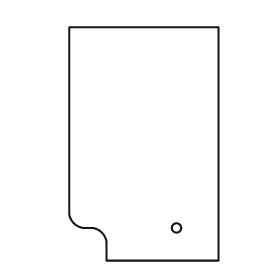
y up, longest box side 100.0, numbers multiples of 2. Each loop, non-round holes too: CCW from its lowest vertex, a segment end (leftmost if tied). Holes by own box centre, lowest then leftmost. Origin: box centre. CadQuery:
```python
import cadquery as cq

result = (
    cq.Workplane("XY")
    .moveTo(-16.0, -50.0)
    .lineTo(32.0, -50.0)
    .lineTo(32.0, 50.0)
    .lineTo(-32.0, 50.0)
    .lineTo(-32.0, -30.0)
    .threePointArc((-30.0, -34.0), (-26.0, -36.0))
    .lineTo(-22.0, -36.0)
    .threePointArc((-18.0, -38.0), (-16.0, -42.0))
    .close()
    .moveTo(14.0, -36.0)
    .circle(2.0)
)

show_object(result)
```